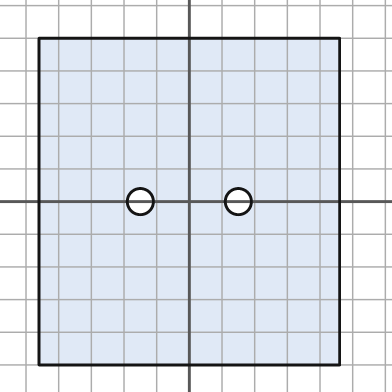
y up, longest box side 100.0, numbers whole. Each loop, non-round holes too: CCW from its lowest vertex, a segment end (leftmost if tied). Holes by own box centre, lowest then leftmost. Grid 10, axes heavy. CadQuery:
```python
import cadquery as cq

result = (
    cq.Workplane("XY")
    .moveTo(-46.0, -50.0)
    .lineTo(46.0, -50.0)
    .lineTo(46.0, 50.0)
    .lineTo(-46.0, 50.0)
    .close()
    .moveTo(-15.0, 0.0)
    .circle(4.0)
    .moveTo(15.0, 0.0)
    .circle(4.0)
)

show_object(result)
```